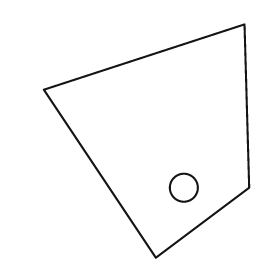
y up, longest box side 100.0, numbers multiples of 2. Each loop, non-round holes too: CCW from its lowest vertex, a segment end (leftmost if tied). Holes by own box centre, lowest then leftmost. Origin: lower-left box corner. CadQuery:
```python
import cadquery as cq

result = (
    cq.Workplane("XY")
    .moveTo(48.0, 0.0)
    .lineTo(88.0, 30.0)
    .lineTo(86.0, 100.0)
    .lineTo(0.0, 72.0)
    .close()
    .moveTo(60.0, 30.0)
    .circle(6.0)
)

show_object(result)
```